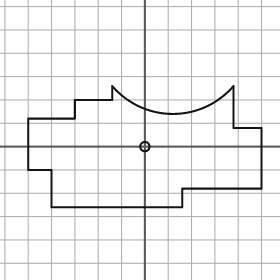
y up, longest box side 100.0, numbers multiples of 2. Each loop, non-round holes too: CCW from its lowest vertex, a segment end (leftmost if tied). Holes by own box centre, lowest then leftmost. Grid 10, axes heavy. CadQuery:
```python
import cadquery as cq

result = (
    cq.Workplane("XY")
    .moveTo(-40.0, -26.0)
    .lineTo(16.0, -26.0)
    .lineTo(16.0, -18.0)
    .lineTo(50.0, -18.0)
    .lineTo(50.0, 8.0)
    .lineTo(38.0, 8.0)
    .lineTo(38.0, 26.0)
    .threePointArc((12.0, 14.0), (-14.0, 26.0))
    .lineTo(-14.0, 20.0)
    .lineTo(-30.0, 20.0)
    .lineTo(-30.0, 12.0)
    .lineTo(-50.0, 12.0)
    .lineTo(-50.0, -10.0)
    .lineTo(-40.0, -10.0)
    .close()
    .moveTo(0.0, 0.0)
    .circle(2.0)
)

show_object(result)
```